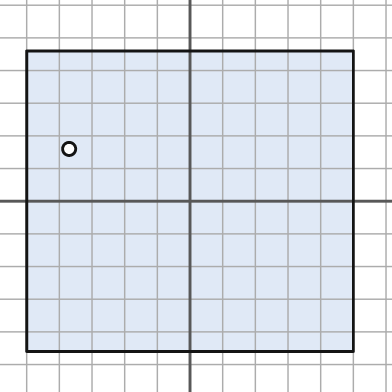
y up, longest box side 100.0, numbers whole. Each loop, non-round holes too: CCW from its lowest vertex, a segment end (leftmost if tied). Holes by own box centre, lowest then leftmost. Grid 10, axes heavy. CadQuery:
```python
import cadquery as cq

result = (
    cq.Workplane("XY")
    .moveTo(-50.0, -46.0)
    .lineTo(50.0, -46.0)
    .lineTo(50.0, 46.0)
    .lineTo(-50.0, 46.0)
    .close()
    .moveTo(-37.0, 16.0)
    .circle(2.0)
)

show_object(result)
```